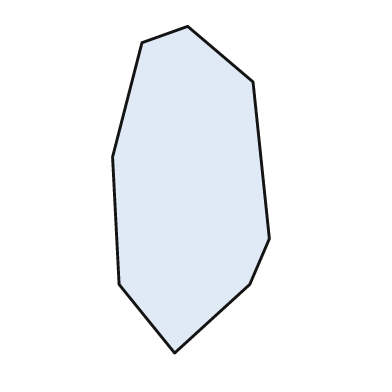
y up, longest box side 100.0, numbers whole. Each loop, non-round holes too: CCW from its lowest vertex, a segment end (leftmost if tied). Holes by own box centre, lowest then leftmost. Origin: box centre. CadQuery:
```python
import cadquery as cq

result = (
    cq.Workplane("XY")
    .moveTo(-5.0, -50.0)
    .lineTo(18.0, -29.0)
    .lineTo(24.0, -15.0)
    .lineTo(19.0, 33.0)
    .lineTo(-1.0, 50.0)
    .lineTo(-15.0, 45.0)
    .lineTo(-24.0, 10.0)
    .lineTo(-22.0, -29.0)
    .close()
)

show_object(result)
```